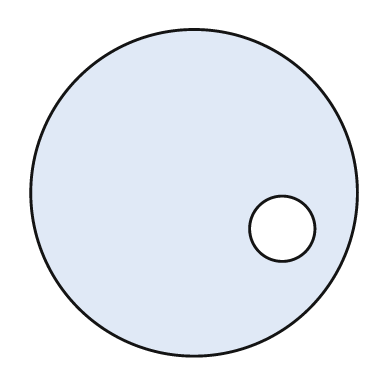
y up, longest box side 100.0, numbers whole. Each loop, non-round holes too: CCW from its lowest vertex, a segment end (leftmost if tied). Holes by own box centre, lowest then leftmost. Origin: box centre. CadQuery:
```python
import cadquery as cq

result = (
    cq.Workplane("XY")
    .moveTo(0.0, 0.0)
    .circle(50.0)
    .moveTo(27.0, -11.0)
    .circle(10.0)
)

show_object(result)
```